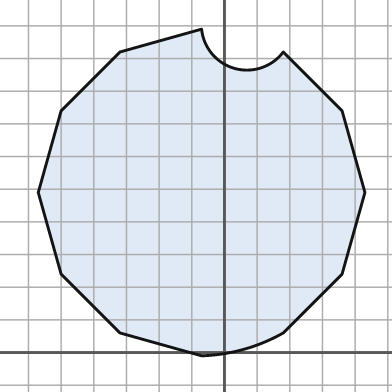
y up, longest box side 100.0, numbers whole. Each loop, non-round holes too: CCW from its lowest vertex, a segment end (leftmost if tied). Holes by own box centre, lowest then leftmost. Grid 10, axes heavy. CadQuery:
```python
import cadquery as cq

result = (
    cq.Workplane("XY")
    .moveTo(-7.0, -1.0)
    .threePointArc((6.0, 1.0), (18.0, 6.0))
    .lineTo(36.0, 24.0)
    .lineTo(43.0, 49.0)
    .lineTo(36.0, 74.0)
    .lineTo(18.0, 92.0)
    .threePointArc((3.0, 87.0), (-7.0, 99.0))
    .lineTo(-32.0, 92.0)
    .lineTo(-50.0, 74.0)
    .lineTo(-57.0, 49.0)
    .lineTo(-50.0, 24.0)
    .lineTo(-32.0, 6.0)
    .close()
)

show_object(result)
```